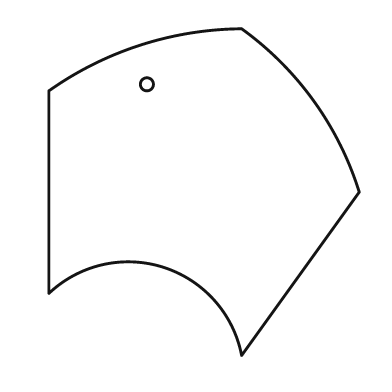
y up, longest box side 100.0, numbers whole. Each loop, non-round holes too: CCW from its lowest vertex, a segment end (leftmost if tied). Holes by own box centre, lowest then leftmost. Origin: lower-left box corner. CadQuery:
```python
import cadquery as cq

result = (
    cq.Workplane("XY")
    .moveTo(59.0, 0.0)
    .lineTo(95.0, 50.0)
    .threePointArc((81.0, 78.0), (59.0, 100.0))
    .threePointArc((28.0, 95.0), (0.0, 81.0))
    .lineTo(0.0, 19.0)
    .threePointArc((35.0, 27.0), (59.0, 0.0))
    .close()
    .moveTo(30.0, 83.0)
    .circle(2.0)
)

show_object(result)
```